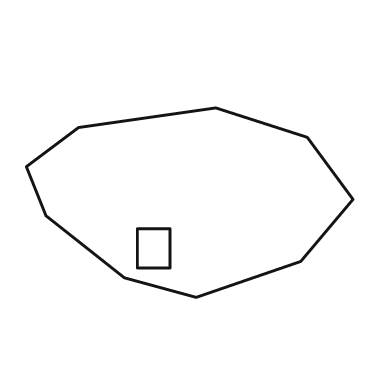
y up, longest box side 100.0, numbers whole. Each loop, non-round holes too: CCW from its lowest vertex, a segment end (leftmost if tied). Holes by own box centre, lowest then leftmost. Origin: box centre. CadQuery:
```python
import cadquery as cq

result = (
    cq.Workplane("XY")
    .moveTo(2.0, -29.0)
    .lineTo(34.0, -18.0)
    .lineTo(50.0, 1.0)
    .lineTo(36.0, 20.0)
    .lineTo(8.0, 29.0)
    .lineTo(-34.0, 23.0)
    .lineTo(-50.0, 11.0)
    .lineTo(-44.0, -4.0)
    .lineTo(-20.0, -23.0)
    .close()
    .moveTo(-16.0, -20.0)
    .lineTo(-6.0, -20.0)
    .lineTo(-6.0, -8.0)
    .lineTo(-16.0, -8.0)
    .close()
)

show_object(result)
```